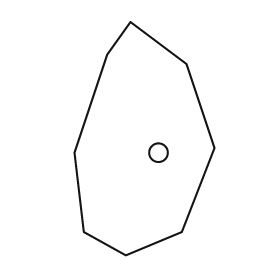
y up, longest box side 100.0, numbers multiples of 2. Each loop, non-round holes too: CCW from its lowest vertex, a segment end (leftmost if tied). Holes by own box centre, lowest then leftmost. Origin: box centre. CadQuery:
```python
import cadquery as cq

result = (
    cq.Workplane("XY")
    .moveTo(-8.0, -50.0)
    .lineTo(16.0, -40.0)
    .lineTo(30.0, -4.0)
    .lineTo(18.0, 32.0)
    .lineTo(-6.0, 50.0)
    .lineTo(-16.0, 36.0)
    .lineTo(-30.0, -6.0)
    .lineTo(-26.0, -40.0)
    .close()
    .moveTo(6.0, -6.0)
    .circle(4.0)
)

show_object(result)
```